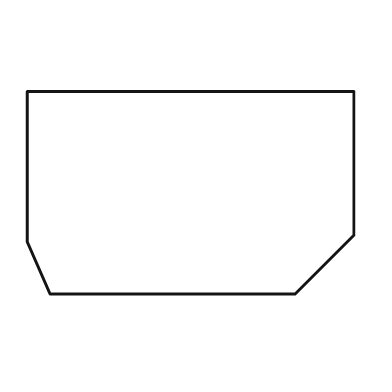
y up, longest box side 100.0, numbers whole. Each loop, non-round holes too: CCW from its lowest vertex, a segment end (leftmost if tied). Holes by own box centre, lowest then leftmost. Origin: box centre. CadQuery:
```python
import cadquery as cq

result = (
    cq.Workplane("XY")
    .moveTo(-43.0, -31.0)
    .lineTo(32.0, -31.0)
    .lineTo(50.0, -13.0)
    .lineTo(50.0, 31.0)
    .lineTo(-50.0, 31.0)
    .lineTo(-50.0, -15.0)
    .close()
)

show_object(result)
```